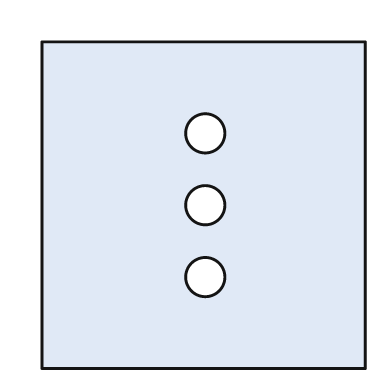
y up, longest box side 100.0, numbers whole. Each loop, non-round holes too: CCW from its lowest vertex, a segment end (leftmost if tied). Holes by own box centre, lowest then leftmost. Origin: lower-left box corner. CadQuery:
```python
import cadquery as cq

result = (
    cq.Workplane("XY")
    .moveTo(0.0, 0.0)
    .lineTo(99.0, 0.0)
    .lineTo(99.0, 100.0)
    .lineTo(0.0, 100.0)
    .close()
    .moveTo(50.0, 28.0)
    .circle(6.0)
    .moveTo(50.0, 50.0)
    .circle(6.0)
    .moveTo(50.0, 72.0)
    .circle(6.0)
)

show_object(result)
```